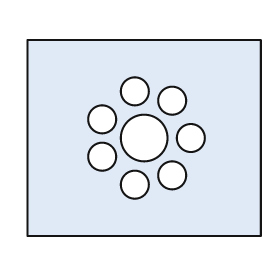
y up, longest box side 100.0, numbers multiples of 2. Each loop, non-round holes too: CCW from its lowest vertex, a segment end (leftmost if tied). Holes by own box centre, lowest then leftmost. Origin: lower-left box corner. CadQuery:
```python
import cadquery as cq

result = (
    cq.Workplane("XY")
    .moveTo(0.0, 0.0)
    .lineTo(100.0, 0.0)
    .lineTo(100.0, 84.0)
    .lineTo(0.0, 84.0)
    .close()
    .moveTo(46.0, 22.0)
    .circle(6.0)
    .moveTo(62.0, 26.0)
    .circle(6.0)
    .moveTo(32.0, 34.0)
    .circle(6.0)
    .moveTo(50.0, 42.0)
    .circle(10.0)
    .moveTo(70.0, 42.0)
    .circle(6.0)
    .moveTo(32.0, 50.0)
    .circle(6.0)
    .moveTo(62.0, 58.0)
    .circle(6.0)
    .moveTo(46.0, 62.0)
    .circle(6.0)
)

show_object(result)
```